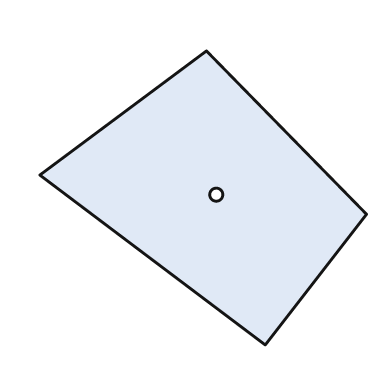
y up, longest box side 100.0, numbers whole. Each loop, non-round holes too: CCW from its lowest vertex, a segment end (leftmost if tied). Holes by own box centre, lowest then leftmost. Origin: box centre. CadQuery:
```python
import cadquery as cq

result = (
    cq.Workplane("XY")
    .moveTo(19.0, -45.0)
    .lineTo(50.0, -5.0)
    .lineTo(1.0, 45.0)
    .lineTo(-50.0, 7.0)
    .close()
    .moveTo(4.0, 1.0)
    .circle(2.0)
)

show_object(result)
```